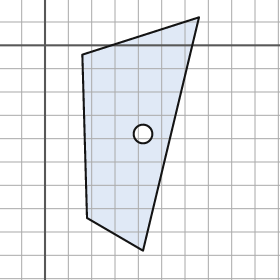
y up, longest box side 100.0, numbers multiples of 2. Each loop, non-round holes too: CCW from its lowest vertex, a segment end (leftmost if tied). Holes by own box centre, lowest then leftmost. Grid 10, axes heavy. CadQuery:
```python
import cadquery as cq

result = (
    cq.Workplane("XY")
    .moveTo(42.0, -88.0)
    .lineTo(66.0, 12.0)
    .lineTo(16.0, -4.0)
    .lineTo(18.0, -74.0)
    .close()
    .moveTo(42.0, -38.0)
    .circle(4.0)
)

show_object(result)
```